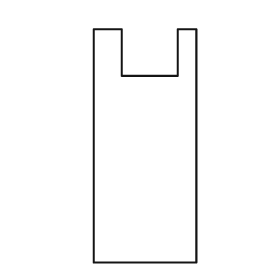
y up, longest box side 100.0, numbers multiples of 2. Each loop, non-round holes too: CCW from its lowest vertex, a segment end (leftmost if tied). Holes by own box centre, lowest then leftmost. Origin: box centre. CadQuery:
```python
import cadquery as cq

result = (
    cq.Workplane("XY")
    .moveTo(-22.0, -50.0)
    .lineTo(22.0, -50.0)
    .lineTo(22.0, 50.0)
    .lineTo(14.0, 50.0)
    .lineTo(14.0, 30.0)
    .lineTo(-10.0, 30.0)
    .lineTo(-10.0, 50.0)
    .lineTo(-22.0, 50.0)
    .close()
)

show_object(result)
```